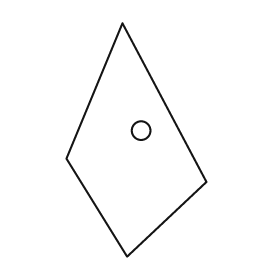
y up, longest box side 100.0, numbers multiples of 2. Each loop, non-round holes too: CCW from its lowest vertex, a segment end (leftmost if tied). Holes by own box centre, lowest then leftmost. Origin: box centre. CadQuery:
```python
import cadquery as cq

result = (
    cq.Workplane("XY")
    .moveTo(-4.0, -50.0)
    .lineTo(30.0, -18.0)
    .lineTo(-6.0, 50.0)
    .lineTo(-30.0, -8.0)
    .close()
    .moveTo(2.0, 4.0)
    .circle(4.0)
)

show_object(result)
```